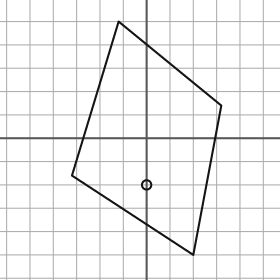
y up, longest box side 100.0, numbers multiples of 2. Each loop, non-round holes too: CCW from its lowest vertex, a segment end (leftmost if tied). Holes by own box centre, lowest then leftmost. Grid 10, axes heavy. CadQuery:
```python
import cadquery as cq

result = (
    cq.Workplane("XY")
    .moveTo(20.0, -50.0)
    .lineTo(32.0, 14.0)
    .lineTo(-12.0, 50.0)
    .lineTo(-32.0, -16.0)
    .close()
    .moveTo(0.0, -20.0)
    .circle(2.0)
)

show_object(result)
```